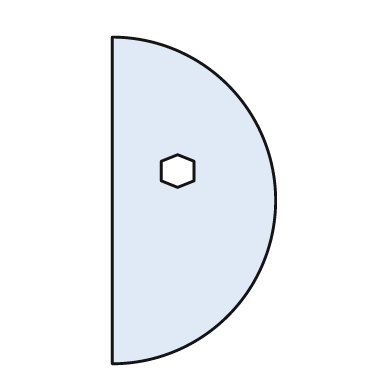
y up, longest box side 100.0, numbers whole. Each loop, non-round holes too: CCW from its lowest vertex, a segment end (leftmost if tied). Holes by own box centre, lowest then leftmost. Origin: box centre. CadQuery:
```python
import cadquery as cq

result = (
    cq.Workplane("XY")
    .moveTo(-25.0, -50.0)
    .threePointArc((25.0, 0.0), (-25.0, 50.0))
    .close()
    .moveTo(-5.0, 4.0)
    .lineTo(0.0, 6.0)
    .lineTo(0.0, 12.0)
    .lineTo(-5.0, 14.0)
    .lineTo(-10.0, 12.0)
    .lineTo(-10.0, 6.0)
    .close()
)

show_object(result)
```